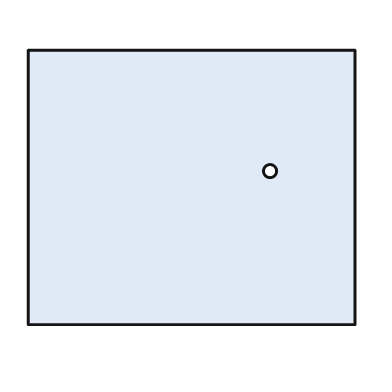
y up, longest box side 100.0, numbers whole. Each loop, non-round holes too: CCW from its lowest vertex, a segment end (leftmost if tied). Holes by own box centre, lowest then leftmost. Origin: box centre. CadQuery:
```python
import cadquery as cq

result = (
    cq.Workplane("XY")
    .moveTo(-50.0, -42.0)
    .lineTo(50.0, -42.0)
    .lineTo(50.0, 42.0)
    .lineTo(-50.0, 42.0)
    .close()
    .moveTo(24.0, 5.0)
    .circle(2.0)
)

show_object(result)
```